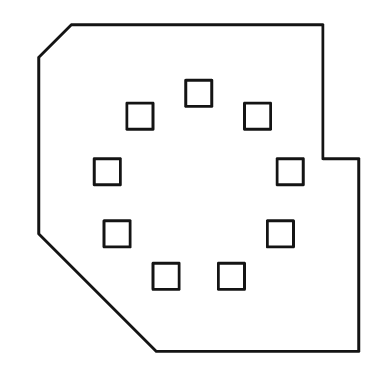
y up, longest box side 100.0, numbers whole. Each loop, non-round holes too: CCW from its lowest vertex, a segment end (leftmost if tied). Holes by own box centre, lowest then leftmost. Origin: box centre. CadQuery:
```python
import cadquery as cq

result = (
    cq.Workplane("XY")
    .moveTo(-13.0, -50.0)
    .lineTo(49.0, -50.0)
    .lineTo(49.0, 9.0)
    .lineTo(38.0, 9.0)
    .lineTo(38.0, 50.0)
    .lineTo(-39.0, 50.0)
    .lineTo(-49.0, 40.0)
    .lineTo(-49.0, -14.0)
    .close()
    .moveTo(-14.0, -31.0)
    .lineTo(-6.0, -31.0)
    .lineTo(-6.0, -23.0)
    .lineTo(-14.0, -23.0)
    .close()
    .moveTo(6.0, -31.0)
    .lineTo(14.0, -31.0)
    .lineTo(14.0, -23.0)
    .lineTo(6.0, -23.0)
    .close()
    .moveTo(-29.0, -18.0)
    .lineTo(-21.0, -18.0)
    .lineTo(-21.0, -10.0)
    .lineTo(-29.0, -10.0)
    .close()
    .moveTo(21.0, -18.0)
    .lineTo(29.0, -18.0)
    .lineTo(29.0, -10.0)
    .lineTo(21.0, -10.0)
    .close()
    .moveTo(-32.0, 1.0)
    .lineTo(-24.0, 1.0)
    .lineTo(-24.0, 9.0)
    .lineTo(-32.0, 9.0)
    .close()
    .moveTo(24.0, 1.0)
    .lineTo(32.0, 1.0)
    .lineTo(32.0, 9.0)
    .lineTo(24.0, 9.0)
    .close()
    .moveTo(-22.0, 18.0)
    .lineTo(-14.0, 18.0)
    .lineTo(-14.0, 26.0)
    .lineTo(-22.0, 26.0)
    .close()
    .moveTo(14.0, 18.0)
    .lineTo(22.0, 18.0)
    .lineTo(22.0, 26.0)
    .lineTo(14.0, 26.0)
    .close()
    .moveTo(-4.0, 25.0)
    .lineTo(4.0, 25.0)
    .lineTo(4.0, 33.0)
    .lineTo(-4.0, 33.0)
    .close()
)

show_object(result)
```